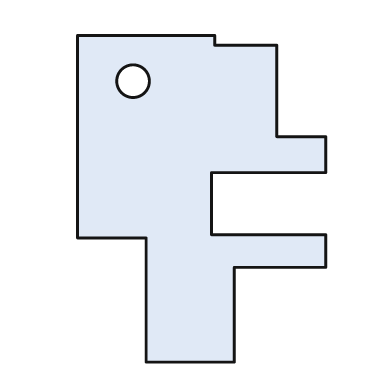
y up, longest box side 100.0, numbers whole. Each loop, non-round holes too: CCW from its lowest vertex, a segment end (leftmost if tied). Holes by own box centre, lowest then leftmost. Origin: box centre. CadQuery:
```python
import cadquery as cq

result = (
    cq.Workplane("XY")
    .moveTo(-17.0, -50.0)
    .lineTo(10.0, -50.0)
    .lineTo(10.0, -21.0)
    .lineTo(38.0, -21.0)
    .lineTo(38.0, -11.0)
    .lineTo(3.0, -11.0)
    .lineTo(3.0, 8.0)
    .lineTo(38.0, 8.0)
    .lineTo(38.0, 19.0)
    .lineTo(23.0, 19.0)
    .lineTo(23.0, 47.0)
    .lineTo(4.0, 47.0)
    .lineTo(4.0, 50.0)
    .lineTo(-38.0, 50.0)
    .lineTo(-38.0, -12.0)
    .lineTo(-17.0, -12.0)
    .close()
    .moveTo(-21.0, 36.0)
    .circle(5.0)
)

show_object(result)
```